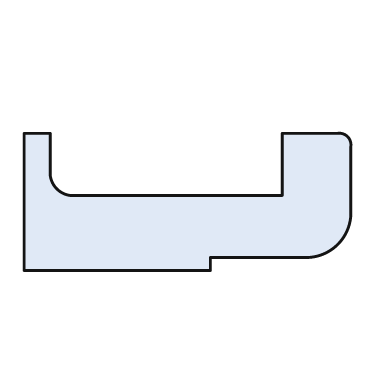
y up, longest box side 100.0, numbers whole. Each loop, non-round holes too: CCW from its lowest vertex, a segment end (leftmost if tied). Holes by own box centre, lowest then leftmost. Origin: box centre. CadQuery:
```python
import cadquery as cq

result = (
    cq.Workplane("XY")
    .moveTo(-50.0, -21.0)
    .lineTo(7.0, -21.0)
    .lineTo(7.0, -17.0)
    .lineTo(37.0, -17.0)
    .threePointArc((46.0, -13.0), (50.0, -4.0))
    .lineTo(50.0, 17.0)
    .threePointArc((49.0, 20.0), (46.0, 21.0))
    .lineTo(29.0, 21.0)
    .lineTo(29.0, 2.0)
    .lineTo(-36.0, 2.0)
    .threePointArc((-40.0, 4.0), (-42.0, 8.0))
    .lineTo(-42.0, 21.0)
    .lineTo(-50.0, 21.0)
    .close()
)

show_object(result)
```